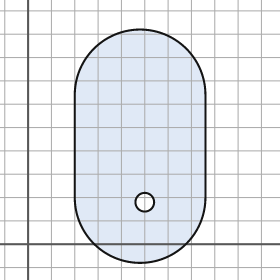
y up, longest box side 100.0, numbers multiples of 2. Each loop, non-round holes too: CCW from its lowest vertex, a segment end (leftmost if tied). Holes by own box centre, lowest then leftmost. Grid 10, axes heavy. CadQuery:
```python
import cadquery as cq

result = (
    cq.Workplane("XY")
    .moveTo(20.0, 20.0)
    .threePointArc((48.0, -8.0), (76.0, 20.0))
    .lineTo(76.0, 64.0)
    .threePointArc((48.0, 92.0), (20.0, 64.0))
    .close()
    .moveTo(50.0, 18.0)
    .circle(4.0)
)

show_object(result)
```